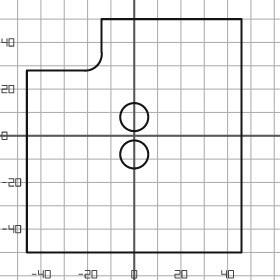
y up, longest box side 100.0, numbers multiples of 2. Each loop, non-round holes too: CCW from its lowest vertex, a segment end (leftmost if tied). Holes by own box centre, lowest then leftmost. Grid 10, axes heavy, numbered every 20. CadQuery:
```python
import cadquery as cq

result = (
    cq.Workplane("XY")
    .moveTo(-46.0, -50.0)
    .lineTo(46.0, -50.0)
    .lineTo(46.0, 50.0)
    .lineTo(-14.0, 50.0)
    .lineTo(-14.0, 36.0)
    .threePointArc((-16.0, 30.0), (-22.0, 28.0))
    .lineTo(-46.0, 28.0)
    .close()
    .moveTo(0.0, -8.0)
    .circle(6.0)
    .moveTo(0.0, 8.0)
    .circle(6.0)
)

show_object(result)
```